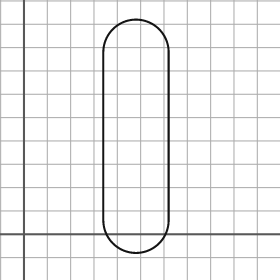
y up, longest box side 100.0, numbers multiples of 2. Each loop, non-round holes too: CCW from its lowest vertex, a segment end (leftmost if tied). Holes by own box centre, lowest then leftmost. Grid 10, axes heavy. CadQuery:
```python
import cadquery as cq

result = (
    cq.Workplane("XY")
    .moveTo(34.0, 6.0)
    .threePointArc((48.0, -8.0), (62.0, 6.0))
    .lineTo(62.0, 78.0)
    .threePointArc((48.0, 92.0), (34.0, 78.0))
    .close()
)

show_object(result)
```